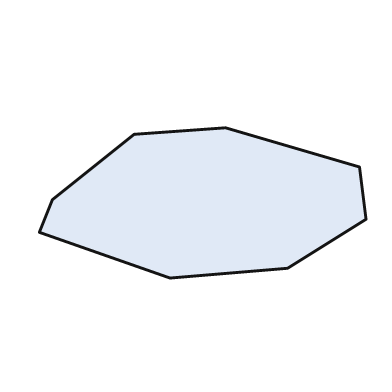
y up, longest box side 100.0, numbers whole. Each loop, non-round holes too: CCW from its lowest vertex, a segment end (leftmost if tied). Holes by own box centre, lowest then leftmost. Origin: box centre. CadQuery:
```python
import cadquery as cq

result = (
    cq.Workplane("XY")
    .moveTo(-10.0, -23.0)
    .lineTo(26.0, -20.0)
    .lineTo(50.0, -5.0)
    .lineTo(48.0, 11.0)
    .lineTo(7.0, 23.0)
    .lineTo(-21.0, 21.0)
    .lineTo(-46.0, 1.0)
    .lineTo(-50.0, -9.0)
    .close()
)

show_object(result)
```